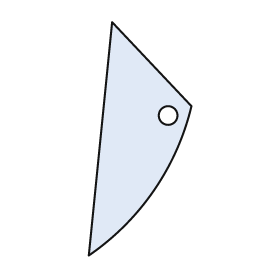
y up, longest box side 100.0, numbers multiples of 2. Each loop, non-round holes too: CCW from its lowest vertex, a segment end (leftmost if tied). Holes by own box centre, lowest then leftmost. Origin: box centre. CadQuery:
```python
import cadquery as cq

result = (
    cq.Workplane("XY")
    .moveTo(-22.0, -50.0)
    .threePointArc((6.0, -22.0), (22.0, 14.0))
    .lineTo(-12.0, 50.0)
    .close()
    .moveTo(12.0, 10.0)
    .circle(4.0)
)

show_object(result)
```